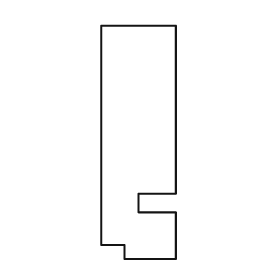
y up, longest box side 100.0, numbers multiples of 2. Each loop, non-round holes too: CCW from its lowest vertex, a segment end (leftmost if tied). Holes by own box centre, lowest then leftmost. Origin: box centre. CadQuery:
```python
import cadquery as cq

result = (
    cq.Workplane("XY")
    .moveTo(-6.0, -50.0)
    .lineTo(16.0, -50.0)
    .lineTo(16.0, -30.0)
    .lineTo(0.0, -30.0)
    .lineTo(0.0, -22.0)
    .lineTo(16.0, -22.0)
    .lineTo(16.0, 50.0)
    .lineTo(-16.0, 50.0)
    .lineTo(-16.0, -44.0)
    .lineTo(-6.0, -44.0)
    .close()
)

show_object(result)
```